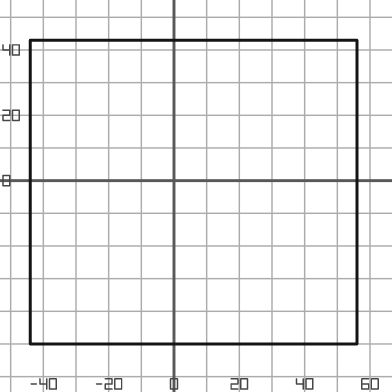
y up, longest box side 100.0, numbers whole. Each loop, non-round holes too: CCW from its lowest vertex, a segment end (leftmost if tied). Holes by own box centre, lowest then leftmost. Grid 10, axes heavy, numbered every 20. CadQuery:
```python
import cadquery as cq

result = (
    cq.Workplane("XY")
    .moveTo(-44.0, -50.0)
    .lineTo(56.0, -50.0)
    .lineTo(56.0, 43.0)
    .lineTo(-44.0, 43.0)
    .close()
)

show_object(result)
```